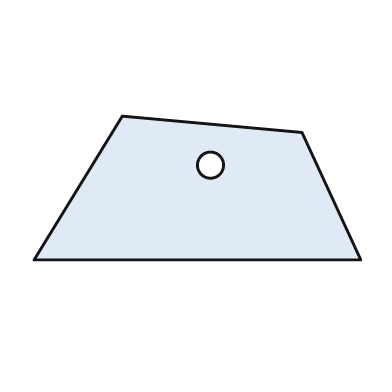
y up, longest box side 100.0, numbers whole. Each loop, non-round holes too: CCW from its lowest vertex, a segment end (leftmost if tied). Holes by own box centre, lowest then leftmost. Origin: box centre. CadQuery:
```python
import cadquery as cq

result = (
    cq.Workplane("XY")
    .moveTo(-50.0, -22.0)
    .lineTo(50.0, -22.0)
    .lineTo(32.0, 17.0)
    .lineTo(-23.0, 22.0)
    .close()
    .moveTo(4.0, 7.0)
    .circle(4.0)
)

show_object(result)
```